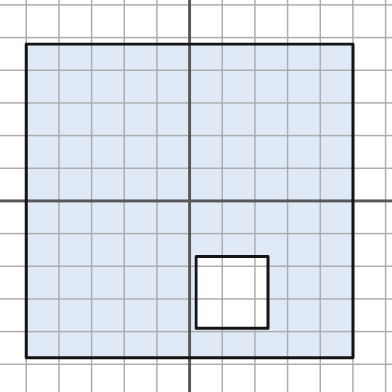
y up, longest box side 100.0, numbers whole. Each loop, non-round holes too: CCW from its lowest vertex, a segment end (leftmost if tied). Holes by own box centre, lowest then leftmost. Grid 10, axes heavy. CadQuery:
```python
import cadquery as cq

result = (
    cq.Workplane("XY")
    .moveTo(-50.0, -48.0)
    .lineTo(50.0, -48.0)
    .lineTo(50.0, 48.0)
    .lineTo(-50.0, 48.0)
    .close()
    .moveTo(2.0, -39.0)
    .lineTo(24.0, -39.0)
    .lineTo(24.0, -17.0)
    .lineTo(2.0, -17.0)
    .close()
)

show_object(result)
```